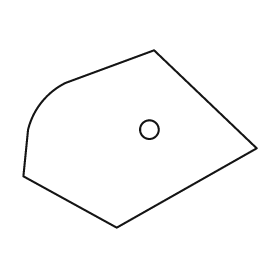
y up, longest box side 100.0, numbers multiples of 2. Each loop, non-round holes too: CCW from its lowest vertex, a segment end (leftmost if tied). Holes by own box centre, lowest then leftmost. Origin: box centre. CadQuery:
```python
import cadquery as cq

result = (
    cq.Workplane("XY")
    .moveTo(-10.0, -38.0)
    .lineTo(50.0, -4.0)
    .lineTo(6.0, 38.0)
    .lineTo(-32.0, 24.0)
    .threePointArc((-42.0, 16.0), (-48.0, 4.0))
    .lineTo(-50.0, -16.0)
    .close()
    .moveTo(4.0, 4.0)
    .circle(4.0)
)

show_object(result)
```